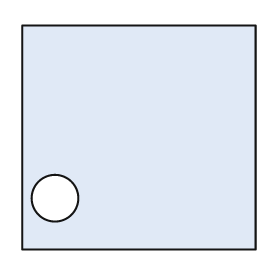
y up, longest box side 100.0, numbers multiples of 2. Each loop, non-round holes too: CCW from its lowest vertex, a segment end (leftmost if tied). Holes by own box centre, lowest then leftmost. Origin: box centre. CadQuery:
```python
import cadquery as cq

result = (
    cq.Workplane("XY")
    .moveTo(-50.0, -48.0)
    .lineTo(50.0, -48.0)
    .lineTo(50.0, 48.0)
    .lineTo(-50.0, 48.0)
    .close()
    .moveTo(-36.0, -26.0)
    .circle(10.0)
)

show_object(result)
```